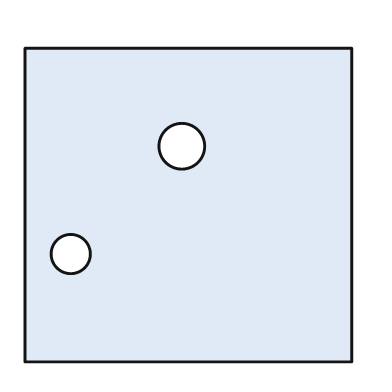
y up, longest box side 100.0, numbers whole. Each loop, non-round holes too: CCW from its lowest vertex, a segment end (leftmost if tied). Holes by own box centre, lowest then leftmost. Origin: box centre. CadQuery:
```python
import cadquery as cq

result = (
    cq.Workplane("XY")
    .moveTo(-50.0, -48.0)
    .lineTo(50.0, -48.0)
    .lineTo(50.0, 48.0)
    .lineTo(-50.0, 48.0)
    .close()
    .moveTo(-36.0, -15.0)
    .circle(6.0)
    .moveTo(-2.0, 18.0)
    .circle(7.0)
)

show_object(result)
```